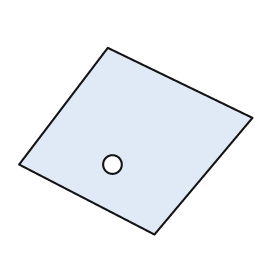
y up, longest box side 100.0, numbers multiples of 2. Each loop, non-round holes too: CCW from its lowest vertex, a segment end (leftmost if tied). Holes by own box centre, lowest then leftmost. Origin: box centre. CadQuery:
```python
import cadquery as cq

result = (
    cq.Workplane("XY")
    .moveTo(8.0, -40.0)
    .lineTo(50.0, 10.0)
    .lineTo(-12.0, 40.0)
    .lineTo(-50.0, -10.0)
    .close()
    .moveTo(-10.0, -10.0)
    .circle(4.0)
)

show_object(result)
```